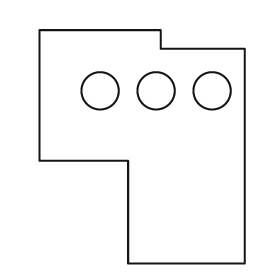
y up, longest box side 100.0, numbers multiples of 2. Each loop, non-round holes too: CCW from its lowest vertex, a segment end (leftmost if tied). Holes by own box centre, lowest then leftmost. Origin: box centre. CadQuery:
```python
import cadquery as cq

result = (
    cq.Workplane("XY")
    .moveTo(-6.0, -50.0)
    .lineTo(44.0, -50.0)
    .lineTo(44.0, 42.0)
    .lineTo(8.0, 42.0)
    .lineTo(8.0, 50.0)
    .lineTo(-44.0, 50.0)
    .lineTo(-44.0, -6.0)
    .lineTo(-6.0, -6.0)
    .close()
    .moveTo(-18.0, 24.0)
    .circle(8.0)
    .moveTo(6.0, 24.0)
    .circle(8.0)
    .moveTo(30.0, 24.0)
    .circle(8.0)
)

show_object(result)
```